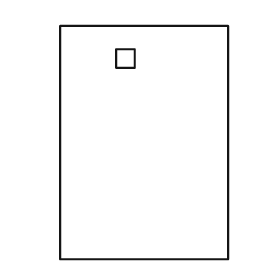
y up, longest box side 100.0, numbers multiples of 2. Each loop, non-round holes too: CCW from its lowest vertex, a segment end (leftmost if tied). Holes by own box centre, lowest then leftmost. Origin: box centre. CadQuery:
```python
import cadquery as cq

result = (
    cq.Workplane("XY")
    .moveTo(-36.0, -50.0)
    .lineTo(36.0, -50.0)
    .lineTo(36.0, 50.0)
    .lineTo(-36.0, 50.0)
    .close()
    .moveTo(-12.0, 32.0)
    .lineTo(-4.0, 32.0)
    .lineTo(-4.0, 40.0)
    .lineTo(-12.0, 40.0)
    .close()
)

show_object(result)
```